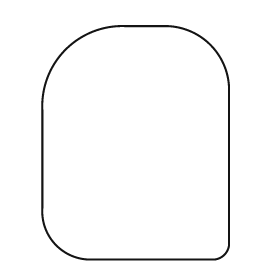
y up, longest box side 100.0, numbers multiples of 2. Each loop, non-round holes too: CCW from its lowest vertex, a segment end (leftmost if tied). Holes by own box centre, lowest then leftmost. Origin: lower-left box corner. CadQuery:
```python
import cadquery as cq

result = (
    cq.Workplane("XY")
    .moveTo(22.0, 0.0)
    .lineTo(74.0, 0.0)
    .threePointArc((78.0, 2.0), (80.0, 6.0))
    .lineTo(80.0, 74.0)
    .threePointArc((72.0, 92.0), (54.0, 100.0))
    .lineTo(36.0, 100.0)
    .threePointArc((10.0, 90.0), (0.0, 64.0))
    .lineTo(0.0, 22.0)
    .threePointArc((6.0, 6.0), (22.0, 0.0))
    .close()
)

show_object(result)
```